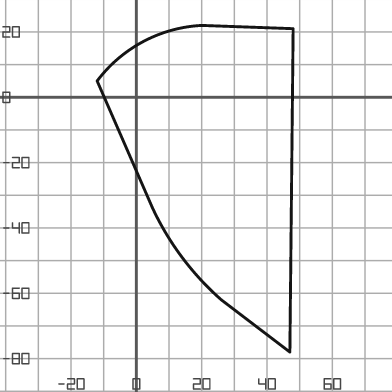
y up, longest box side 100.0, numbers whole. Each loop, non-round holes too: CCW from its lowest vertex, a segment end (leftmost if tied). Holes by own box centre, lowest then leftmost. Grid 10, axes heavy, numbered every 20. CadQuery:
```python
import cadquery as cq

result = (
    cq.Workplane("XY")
    .moveTo(47.0, -78.0)
    .lineTo(48.0, 21.0)
    .lineTo(20.0, 22.0)
    .threePointArc((2.0, 17.0), (-12.0, 5.0))
    .lineTo(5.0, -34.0)
    .threePointArc((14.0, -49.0), (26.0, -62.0))
    .close()
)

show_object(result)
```